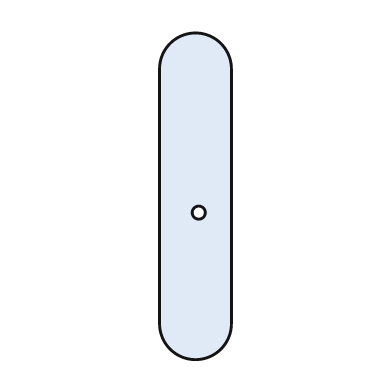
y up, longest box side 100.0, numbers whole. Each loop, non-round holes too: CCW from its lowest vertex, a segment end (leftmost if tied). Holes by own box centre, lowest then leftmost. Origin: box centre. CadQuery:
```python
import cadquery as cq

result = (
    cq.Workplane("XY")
    .moveTo(-11.0, -39.0)
    .threePointArc((0.0, -50.0), (11.0, -39.0))
    .lineTo(11.0, 39.0)
    .threePointArc((0.0, 50.0), (-11.0, 39.0))
    .close()
    .moveTo(1.0, -5.0)
    .circle(2.0)
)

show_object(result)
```